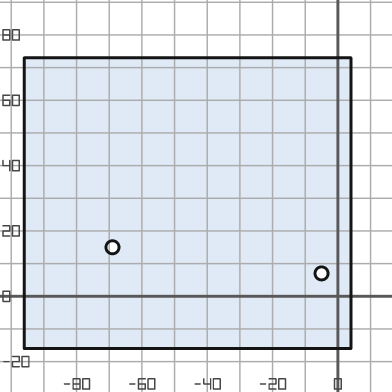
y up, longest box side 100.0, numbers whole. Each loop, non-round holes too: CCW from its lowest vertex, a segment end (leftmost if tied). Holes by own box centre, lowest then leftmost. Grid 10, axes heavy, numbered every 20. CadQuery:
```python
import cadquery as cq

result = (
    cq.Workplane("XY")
    .moveTo(-96.0, -16.0)
    .lineTo(4.0, -16.0)
    .lineTo(4.0, 73.0)
    .lineTo(-96.0, 73.0)
    .close()
    .moveTo(-5.0, 7.0)
    .circle(2.0)
    .moveTo(-69.0, 15.0)
    .circle(2.0)
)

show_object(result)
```